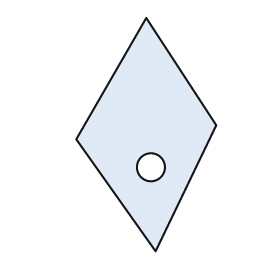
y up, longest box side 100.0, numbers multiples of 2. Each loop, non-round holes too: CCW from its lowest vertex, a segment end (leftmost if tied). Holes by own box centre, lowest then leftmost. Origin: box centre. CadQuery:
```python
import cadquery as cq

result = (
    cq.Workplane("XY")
    .moveTo(4.0, -50.0)
    .lineTo(30.0, 4.0)
    .lineTo(0.0, 50.0)
    .lineTo(-30.0, -2.0)
    .close()
    .moveTo(2.0, -14.0)
    .circle(6.0)
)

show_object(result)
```